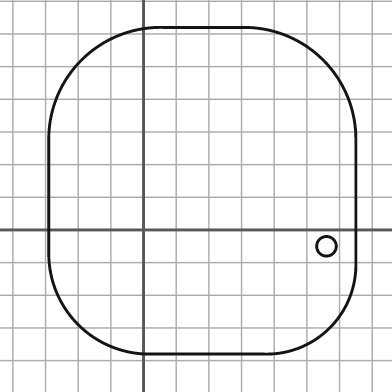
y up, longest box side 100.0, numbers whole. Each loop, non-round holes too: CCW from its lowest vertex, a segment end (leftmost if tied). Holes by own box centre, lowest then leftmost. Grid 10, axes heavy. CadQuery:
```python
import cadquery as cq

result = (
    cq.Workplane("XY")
    .moveTo(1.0, -38.0)
    .lineTo(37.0, -38.0)
    .threePointArc((57.0, -30.0), (65.0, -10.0))
    .lineTo(65.0, 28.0)
    .threePointArc((55.0, 52.0), (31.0, 62.0))
    .lineTo(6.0, 62.0)
    .threePointArc((-19.0, 52.0), (-29.0, 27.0))
    .lineTo(-29.0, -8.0)
    .threePointArc((-20.0, -29.0), (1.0, -38.0))
    .close()
    .moveTo(56.0, -5.0)
    .circle(3.0)
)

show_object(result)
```